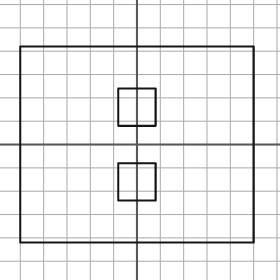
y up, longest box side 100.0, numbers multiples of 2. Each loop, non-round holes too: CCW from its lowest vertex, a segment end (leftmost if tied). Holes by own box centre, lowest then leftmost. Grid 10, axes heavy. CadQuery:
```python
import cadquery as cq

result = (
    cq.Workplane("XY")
    .moveTo(-50.0, -42.0)
    .lineTo(50.0, -42.0)
    .lineTo(50.0, 42.0)
    .lineTo(-50.0, 42.0)
    .close()
    .moveTo(-8.0, -24.0)
    .lineTo(8.0, -24.0)
    .lineTo(8.0, -8.0)
    .lineTo(-8.0, -8.0)
    .close()
    .moveTo(-8.0, 8.0)
    .lineTo(8.0, 8.0)
    .lineTo(8.0, 24.0)
    .lineTo(-8.0, 24.0)
    .close()
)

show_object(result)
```